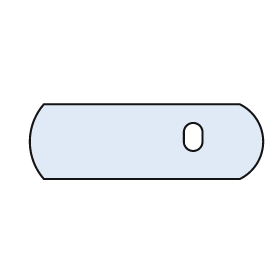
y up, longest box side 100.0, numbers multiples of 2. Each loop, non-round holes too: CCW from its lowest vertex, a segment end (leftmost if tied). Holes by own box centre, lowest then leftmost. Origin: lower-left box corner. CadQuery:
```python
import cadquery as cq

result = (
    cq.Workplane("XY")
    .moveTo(6.0, 0.0)
    .lineTo(90.0, 0.0)
    .threePointArc((100.0, 16.0), (90.0, 32.0))
    .lineTo(6.0, 32.0)
    .threePointArc((0.0, 16.0), (6.0, 0.0))
    .close()
    .moveTo(66.0, 16.0)
    .threePointArc((70.0, 12.0), (74.0, 16.0))
    .lineTo(74.0, 20.0)
    .threePointArc((70.0, 24.0), (66.0, 20.0))
    .close()
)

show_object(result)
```